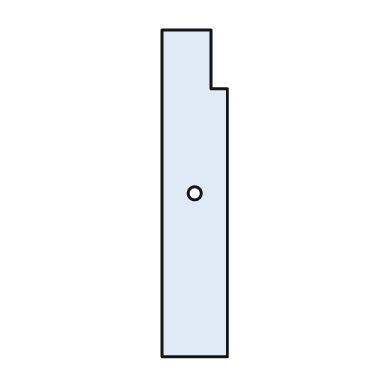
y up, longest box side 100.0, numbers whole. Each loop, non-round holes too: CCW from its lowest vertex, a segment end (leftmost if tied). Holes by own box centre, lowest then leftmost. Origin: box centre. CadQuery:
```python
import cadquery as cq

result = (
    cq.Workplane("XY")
    .moveTo(-10.0, -50.0)
    .lineTo(10.0, -50.0)
    .lineTo(10.0, 32.0)
    .lineTo(5.0, 32.0)
    .lineTo(5.0, 50.0)
    .lineTo(-10.0, 50.0)
    .close()
    .moveTo(0.0, 0.0)
    .circle(2.0)
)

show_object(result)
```